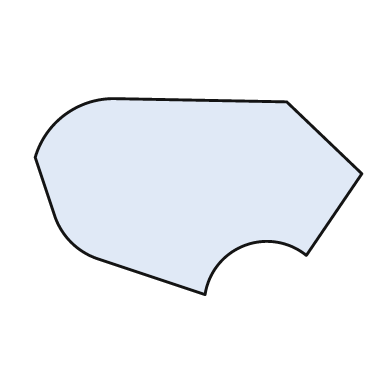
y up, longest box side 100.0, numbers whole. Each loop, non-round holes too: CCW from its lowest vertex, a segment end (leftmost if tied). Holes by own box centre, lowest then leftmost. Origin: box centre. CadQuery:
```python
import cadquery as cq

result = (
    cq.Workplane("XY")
    .moveTo(2.0, -30.0)
    .threePointArc((14.0, -15.0), (33.0, -18.0))
    .lineTo(50.0, 7.0)
    .lineTo(27.0, 29.0)
    .lineTo(-26.0, 30.0)
    .threePointArc((-41.0, 25.0), (-50.0, 12.0))
    .lineTo(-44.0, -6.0)
    .threePointArc((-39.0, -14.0), (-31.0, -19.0))
    .close()
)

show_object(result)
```